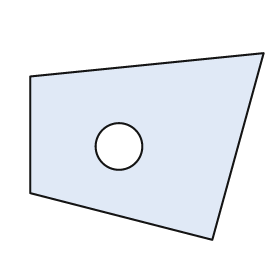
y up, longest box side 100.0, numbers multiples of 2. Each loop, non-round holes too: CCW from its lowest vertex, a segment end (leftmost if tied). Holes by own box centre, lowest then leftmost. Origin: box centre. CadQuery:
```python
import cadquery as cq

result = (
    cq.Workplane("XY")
    .moveTo(28.0, -40.0)
    .lineTo(50.0, 40.0)
    .lineTo(-50.0, 30.0)
    .lineTo(-50.0, -20.0)
    .close()
    .moveTo(-12.0, 0.0)
    .circle(10.0)
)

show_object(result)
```